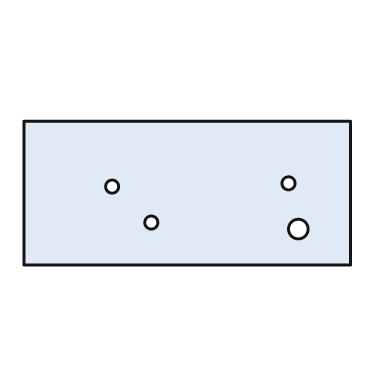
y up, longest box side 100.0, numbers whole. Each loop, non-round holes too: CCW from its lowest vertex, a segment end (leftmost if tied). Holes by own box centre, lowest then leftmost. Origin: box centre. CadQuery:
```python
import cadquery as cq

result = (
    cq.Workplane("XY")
    .moveTo(-50.0, -22.0)
    .lineTo(50.0, -22.0)
    .lineTo(50.0, 22.0)
    .lineTo(-50.0, 22.0)
    .close()
    .moveTo(34.0, -11.0)
    .circle(3.0)
    .moveTo(-11.0, -9.0)
    .circle(2.0)
    .moveTo(-23.0, 2.0)
    .circle(2.0)
    .moveTo(31.0, 3.0)
    .circle(2.0)
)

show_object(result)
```